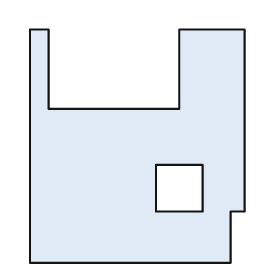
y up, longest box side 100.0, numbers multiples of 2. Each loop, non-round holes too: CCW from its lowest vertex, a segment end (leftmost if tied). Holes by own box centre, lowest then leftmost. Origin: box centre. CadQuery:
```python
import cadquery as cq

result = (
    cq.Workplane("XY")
    .moveTo(-46.0, -50.0)
    .lineTo(40.0, -50.0)
    .lineTo(40.0, -28.0)
    .lineTo(46.0, -28.0)
    .lineTo(46.0, 50.0)
    .lineTo(18.0, 50.0)
    .lineTo(18.0, 16.0)
    .lineTo(-38.0, 16.0)
    .lineTo(-38.0, 50.0)
    .lineTo(-46.0, 50.0)
    .close()
    .moveTo(8.0, -28.0)
    .lineTo(28.0, -28.0)
    .lineTo(28.0, -8.0)
    .lineTo(8.0, -8.0)
    .close()
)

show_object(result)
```